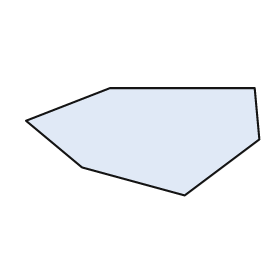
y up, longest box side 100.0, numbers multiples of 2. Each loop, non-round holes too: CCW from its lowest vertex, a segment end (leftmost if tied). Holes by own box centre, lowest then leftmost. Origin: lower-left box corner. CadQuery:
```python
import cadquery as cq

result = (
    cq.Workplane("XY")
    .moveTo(68.0, 0.0)
    .lineTo(100.0, 24.0)
    .lineTo(98.0, 46.0)
    .lineTo(36.0, 46.0)
    .lineTo(0.0, 32.0)
    .lineTo(24.0, 12.0)
    .close()
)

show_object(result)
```